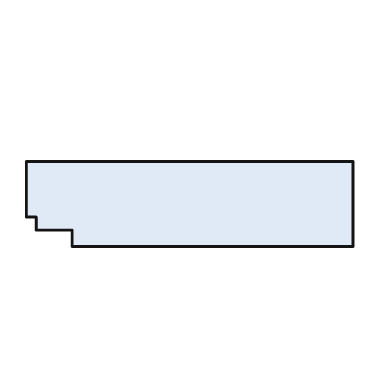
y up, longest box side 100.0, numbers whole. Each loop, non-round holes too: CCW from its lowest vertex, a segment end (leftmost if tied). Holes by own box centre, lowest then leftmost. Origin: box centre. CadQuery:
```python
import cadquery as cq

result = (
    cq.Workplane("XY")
    .moveTo(-36.0, -13.0)
    .lineTo(50.0, -13.0)
    .lineTo(50.0, 13.0)
    .lineTo(-50.0, 13.0)
    .lineTo(-50.0, -4.0)
    .lineTo(-47.0, -4.0)
    .lineTo(-47.0, -8.0)
    .lineTo(-36.0, -8.0)
    .close()
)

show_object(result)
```